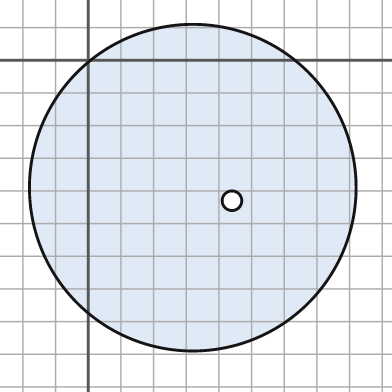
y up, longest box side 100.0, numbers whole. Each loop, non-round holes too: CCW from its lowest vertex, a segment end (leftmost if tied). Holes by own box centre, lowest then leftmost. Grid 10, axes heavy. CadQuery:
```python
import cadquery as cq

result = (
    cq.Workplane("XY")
    .moveTo(32.0, -39.0)
    .circle(50.0)
    .moveTo(44.0, -43.0)
    .circle(3.0)
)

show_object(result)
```